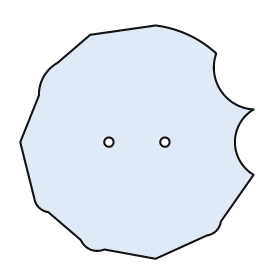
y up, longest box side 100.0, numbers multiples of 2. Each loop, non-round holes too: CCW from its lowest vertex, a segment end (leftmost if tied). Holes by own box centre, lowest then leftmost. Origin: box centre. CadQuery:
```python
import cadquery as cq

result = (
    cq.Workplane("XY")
    .moveTo(8.0, -50.0)
    .lineTo(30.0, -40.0)
    .threePointArc((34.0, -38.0), (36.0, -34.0))
    .lineTo(50.0, -14.0)
    .threePointArc((42.0, 0.0), (50.0, 14.0))
    .threePointArc((36.0, 22.0), (34.0, 38.0))
    .threePointArc((22.0, 46.0), (8.0, 50.0))
    .lineTo(-20.0, 46.0)
    .lineTo(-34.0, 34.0)
    .threePointArc((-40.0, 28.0), (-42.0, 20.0))
    .lineTo(-50.0, 0.0)
    .lineTo(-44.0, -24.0)
    .threePointArc((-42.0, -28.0), (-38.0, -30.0))
    .lineTo(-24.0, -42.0)
    .threePointArc((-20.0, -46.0), (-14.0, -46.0))
    .close()
    .moveTo(-12.0, 0.0)
    .circle(2.0)
    .moveTo(12.0, 0.0)
    .circle(2.0)
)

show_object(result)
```